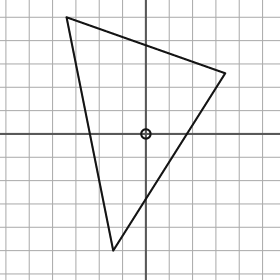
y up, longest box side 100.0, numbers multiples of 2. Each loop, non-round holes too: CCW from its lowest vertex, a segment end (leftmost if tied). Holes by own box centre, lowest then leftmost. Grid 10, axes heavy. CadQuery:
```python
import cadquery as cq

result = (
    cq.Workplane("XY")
    .moveTo(-14.0, -50.0)
    .lineTo(34.0, 26.0)
    .lineTo(-34.0, 50.0)
    .close()
    .moveTo(0.0, 0.0)
    .circle(2.0)
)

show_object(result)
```